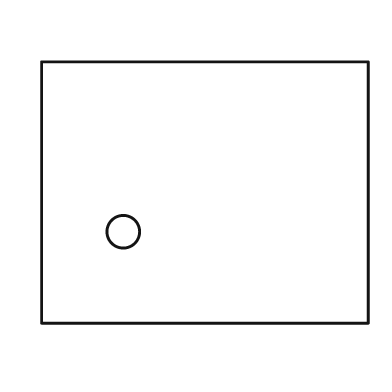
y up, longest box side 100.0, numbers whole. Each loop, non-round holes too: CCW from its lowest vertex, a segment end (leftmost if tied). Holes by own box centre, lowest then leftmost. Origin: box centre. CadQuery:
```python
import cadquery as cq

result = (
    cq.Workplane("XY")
    .moveTo(-50.0, -40.0)
    .lineTo(50.0, -40.0)
    .lineTo(50.0, 40.0)
    .lineTo(-50.0, 40.0)
    .close()
    .moveTo(-25.0, -12.0)
    .circle(5.0)
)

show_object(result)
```